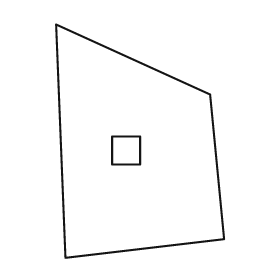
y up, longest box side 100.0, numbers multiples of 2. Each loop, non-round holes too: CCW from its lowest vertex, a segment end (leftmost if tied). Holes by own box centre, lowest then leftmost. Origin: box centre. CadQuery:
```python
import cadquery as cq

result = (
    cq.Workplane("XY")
    .moveTo(-32.0, -50.0)
    .lineTo(36.0, -42.0)
    .lineTo(30.0, 20.0)
    .lineTo(-36.0, 50.0)
    .close()
    .moveTo(-12.0, -10.0)
    .lineTo(0.0, -10.0)
    .lineTo(0.0, 2.0)
    .lineTo(-12.0, 2.0)
    .close()
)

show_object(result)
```